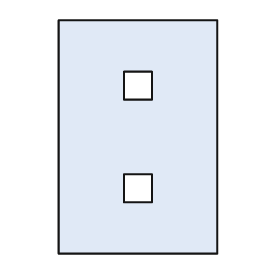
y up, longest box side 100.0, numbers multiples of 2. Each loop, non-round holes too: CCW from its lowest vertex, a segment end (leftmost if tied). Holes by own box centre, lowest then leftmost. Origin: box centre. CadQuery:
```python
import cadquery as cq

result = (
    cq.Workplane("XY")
    .moveTo(-34.0, -50.0)
    .lineTo(34.0, -50.0)
    .lineTo(34.0, 50.0)
    .lineTo(-34.0, 50.0)
    .close()
    .moveTo(-6.0, -28.0)
    .lineTo(6.0, -28.0)
    .lineTo(6.0, -16.0)
    .lineTo(-6.0, -16.0)
    .close()
    .moveTo(-6.0, 16.0)
    .lineTo(6.0, 16.0)
    .lineTo(6.0, 28.0)
    .lineTo(-6.0, 28.0)
    .close()
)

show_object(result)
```